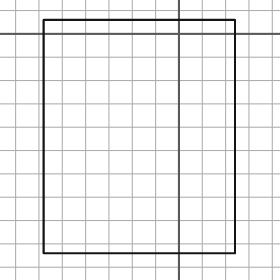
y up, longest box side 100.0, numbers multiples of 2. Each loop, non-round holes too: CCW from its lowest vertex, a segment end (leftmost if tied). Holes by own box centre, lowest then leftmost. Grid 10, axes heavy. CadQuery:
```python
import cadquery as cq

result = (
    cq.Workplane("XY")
    .moveTo(-58.0, -94.0)
    .lineTo(24.0, -94.0)
    .lineTo(24.0, 6.0)
    .lineTo(-58.0, 6.0)
    .close()
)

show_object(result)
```